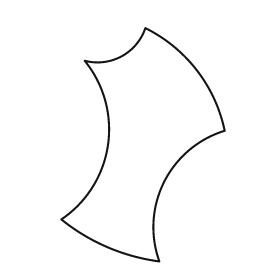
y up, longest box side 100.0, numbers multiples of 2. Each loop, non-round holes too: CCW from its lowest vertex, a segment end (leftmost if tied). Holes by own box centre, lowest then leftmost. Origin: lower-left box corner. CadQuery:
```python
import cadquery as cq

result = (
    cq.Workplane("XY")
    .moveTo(42.0, 0.0)
    .threePointArc((44.0, 34.0), (70.0, 56.0))
    .threePointArc((58.0, 82.0), (36.0, 100.0))
    .threePointArc((26.0, 88.0), (10.0, 86.0))
    .threePointArc((20.0, 50.0), (0.0, 18.0))
    .threePointArc((20.0, 6.0), (42.0, 0.0))
    .close()
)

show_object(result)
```